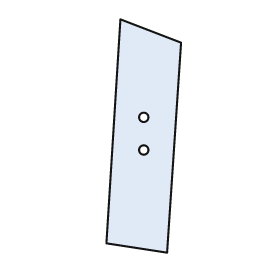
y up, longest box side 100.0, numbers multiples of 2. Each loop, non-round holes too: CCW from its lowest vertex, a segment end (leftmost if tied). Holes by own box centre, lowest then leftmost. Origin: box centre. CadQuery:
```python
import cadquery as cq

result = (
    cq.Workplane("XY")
    .moveTo(10.0, -50.0)
    .lineTo(16.0, 40.0)
    .lineTo(-10.0, 50.0)
    .lineTo(-16.0, -46.0)
    .close()
    .moveTo(0.0, -6.0)
    .circle(2.0)
    .moveTo(0.0, 8.0)
    .circle(2.0)
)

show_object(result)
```